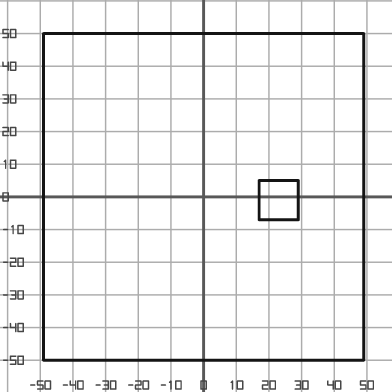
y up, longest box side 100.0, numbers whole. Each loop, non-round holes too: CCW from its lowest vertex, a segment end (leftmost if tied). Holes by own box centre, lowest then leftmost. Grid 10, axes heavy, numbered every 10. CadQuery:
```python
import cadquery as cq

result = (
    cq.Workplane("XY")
    .moveTo(-49.0, -50.0)
    .lineTo(49.0, -50.0)
    .lineTo(49.0, 50.0)
    .lineTo(-49.0, 50.0)
    .close()
    .moveTo(17.0, -7.0)
    .lineTo(29.0, -7.0)
    .lineTo(29.0, 5.0)
    .lineTo(17.0, 5.0)
    .close()
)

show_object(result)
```